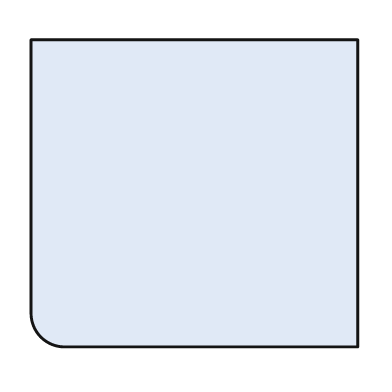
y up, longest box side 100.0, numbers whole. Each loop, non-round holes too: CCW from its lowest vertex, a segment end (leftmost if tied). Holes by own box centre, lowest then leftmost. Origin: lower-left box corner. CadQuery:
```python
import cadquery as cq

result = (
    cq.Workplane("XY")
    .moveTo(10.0, 0.0)
    .lineTo(100.0, 0.0)
    .lineTo(100.0, 94.0)
    .lineTo(0.0, 94.0)
    .lineTo(0.0, 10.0)
    .threePointArc((3.0, 3.0), (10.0, 0.0))
    .close()
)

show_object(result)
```